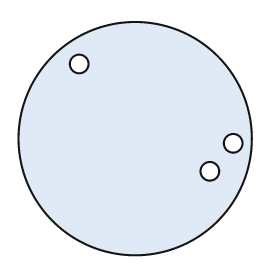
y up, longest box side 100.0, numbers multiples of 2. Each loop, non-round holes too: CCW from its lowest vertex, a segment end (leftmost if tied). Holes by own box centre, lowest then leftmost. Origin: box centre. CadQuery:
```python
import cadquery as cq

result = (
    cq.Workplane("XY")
    .moveTo(0.0, 0.0)
    .circle(50.0)
    .moveTo(32.0, -14.0)
    .circle(4.0)
    .moveTo(42.0, -2.0)
    .circle(4.0)
    .moveTo(-24.0, 32.0)
    .circle(4.0)
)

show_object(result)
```